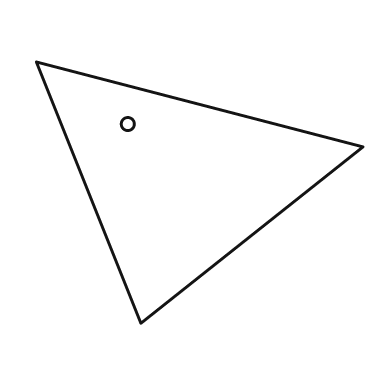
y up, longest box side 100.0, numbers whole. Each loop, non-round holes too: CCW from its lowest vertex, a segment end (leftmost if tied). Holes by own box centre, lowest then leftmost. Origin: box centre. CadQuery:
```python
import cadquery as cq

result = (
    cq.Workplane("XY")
    .moveTo(-18.0, -40.0)
    .lineTo(50.0, 14.0)
    .lineTo(-50.0, 40.0)
    .close()
    .moveTo(-22.0, 21.0)
    .circle(2.0)
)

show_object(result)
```